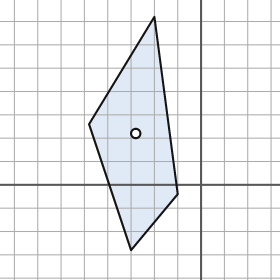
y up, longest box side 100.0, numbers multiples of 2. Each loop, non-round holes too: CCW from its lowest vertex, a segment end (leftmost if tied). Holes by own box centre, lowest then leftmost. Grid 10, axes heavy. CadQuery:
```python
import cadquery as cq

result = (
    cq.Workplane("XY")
    .moveTo(-30.0, -28.0)
    .lineTo(-10.0, -4.0)
    .lineTo(-20.0, 72.0)
    .lineTo(-48.0, 26.0)
    .close()
    .moveTo(-28.0, 22.0)
    .circle(2.0)
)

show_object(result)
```